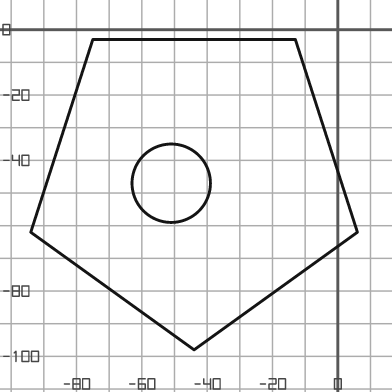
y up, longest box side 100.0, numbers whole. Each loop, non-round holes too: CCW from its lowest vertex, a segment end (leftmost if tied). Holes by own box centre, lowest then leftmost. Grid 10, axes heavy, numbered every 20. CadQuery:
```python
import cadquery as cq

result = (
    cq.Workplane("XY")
    .moveTo(-44.0, -98.0)
    .lineTo(6.0, -62.0)
    .lineTo(-13.0, -3.0)
    .lineTo(-75.0, -3.0)
    .lineTo(-94.0, -62.0)
    .close()
    .moveTo(-51.0, -47.0)
    .circle(12.0)
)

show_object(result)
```